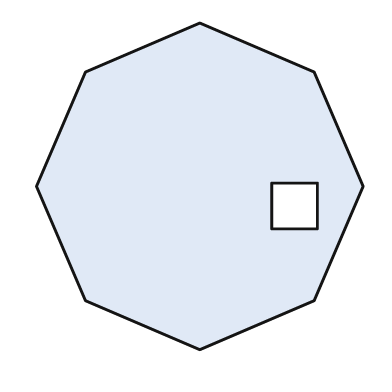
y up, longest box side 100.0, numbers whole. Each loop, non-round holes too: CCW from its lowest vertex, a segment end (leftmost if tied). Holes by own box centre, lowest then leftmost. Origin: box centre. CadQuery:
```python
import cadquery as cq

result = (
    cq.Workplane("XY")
    .moveTo(0.0, -50.0)
    .lineTo(35.0, -35.0)
    .lineTo(50.0, 0.0)
    .lineTo(35.0, 35.0)
    .lineTo(0.0, 50.0)
    .lineTo(-35.0, 35.0)
    .lineTo(-50.0, 0.0)
    .lineTo(-35.0, -35.0)
    .close()
    .moveTo(22.0, -13.0)
    .lineTo(36.0, -13.0)
    .lineTo(36.0, 1.0)
    .lineTo(22.0, 1.0)
    .close()
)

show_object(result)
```